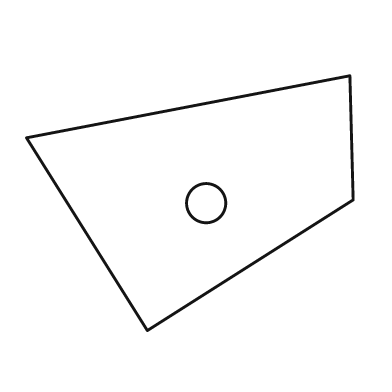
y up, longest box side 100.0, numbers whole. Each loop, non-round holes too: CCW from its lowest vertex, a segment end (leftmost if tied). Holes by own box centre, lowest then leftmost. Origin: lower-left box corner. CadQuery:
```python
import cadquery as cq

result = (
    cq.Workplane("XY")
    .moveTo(37.0, 0.0)
    .lineTo(100.0, 40.0)
    .lineTo(99.0, 78.0)
    .lineTo(0.0, 59.0)
    .close()
    .moveTo(55.0, 39.0)
    .circle(6.0)
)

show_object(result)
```